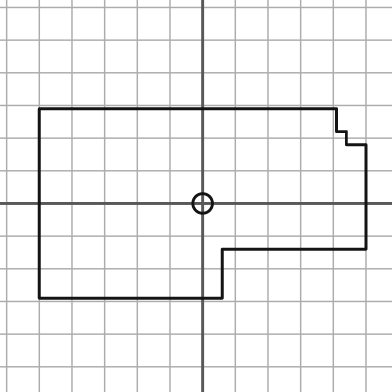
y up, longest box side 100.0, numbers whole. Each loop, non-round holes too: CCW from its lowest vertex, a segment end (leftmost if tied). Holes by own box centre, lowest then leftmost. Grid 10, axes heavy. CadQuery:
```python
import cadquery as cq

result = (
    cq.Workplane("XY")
    .moveTo(-50.0, -29.0)
    .lineTo(6.0, -29.0)
    .lineTo(6.0, -14.0)
    .lineTo(50.0, -14.0)
    .lineTo(50.0, 18.0)
    .lineTo(44.0, 18.0)
    .lineTo(44.0, 22.0)
    .lineTo(41.0, 22.0)
    .lineTo(41.0, 29.0)
    .lineTo(-50.0, 29.0)
    .close()
    .moveTo(0.0, 0.0)
    .circle(3.0)
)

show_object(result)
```